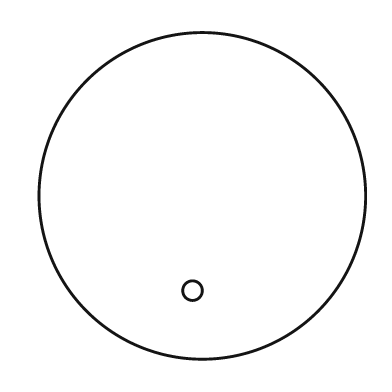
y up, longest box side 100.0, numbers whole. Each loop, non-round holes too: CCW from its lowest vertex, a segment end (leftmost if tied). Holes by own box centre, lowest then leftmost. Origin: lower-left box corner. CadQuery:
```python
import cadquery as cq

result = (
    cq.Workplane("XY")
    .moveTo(50.0, 50.0)
    .circle(50.0)
    .moveTo(47.0, 21.0)
    .circle(3.0)
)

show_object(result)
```